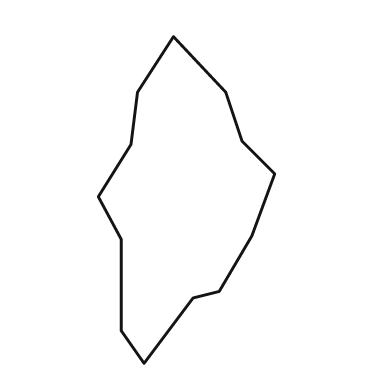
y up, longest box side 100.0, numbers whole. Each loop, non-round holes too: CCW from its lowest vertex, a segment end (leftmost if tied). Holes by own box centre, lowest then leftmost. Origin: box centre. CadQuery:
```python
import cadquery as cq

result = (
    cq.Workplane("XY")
    .moveTo(-13.0, -50.0)
    .lineTo(2.0, -30.0)
    .lineTo(10.0, -28.0)
    .lineTo(20.0, -11.0)
    .lineTo(27.0, 8.0)
    .lineTo(17.0, 18.0)
    .lineTo(12.0, 33.0)
    .lineTo(-4.0, 50.0)
    .lineTo(-15.0, 33.0)
    .lineTo(-17.0, 17.0)
    .lineTo(-27.0, 1.0)
    .lineTo(-20.0, -12.0)
    .lineTo(-20.0, -40.0)
    .close()
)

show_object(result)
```